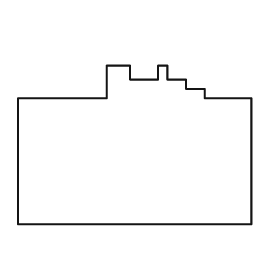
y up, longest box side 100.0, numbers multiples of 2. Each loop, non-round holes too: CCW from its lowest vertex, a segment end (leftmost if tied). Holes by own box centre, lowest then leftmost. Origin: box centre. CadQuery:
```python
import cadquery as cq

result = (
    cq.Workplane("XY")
    .moveTo(-50.0, -34.0)
    .lineTo(50.0, -34.0)
    .lineTo(50.0, 20.0)
    .lineTo(30.0, 20.0)
    .lineTo(30.0, 24.0)
    .lineTo(22.0, 24.0)
    .lineTo(22.0, 28.0)
    .lineTo(14.0, 28.0)
    .lineTo(14.0, 34.0)
    .lineTo(10.0, 34.0)
    .lineTo(10.0, 28.0)
    .lineTo(-2.0, 28.0)
    .lineTo(-2.0, 34.0)
    .lineTo(-12.0, 34.0)
    .lineTo(-12.0, 20.0)
    .lineTo(-50.0, 20.0)
    .close()
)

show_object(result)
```